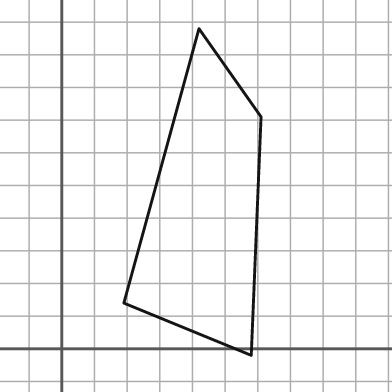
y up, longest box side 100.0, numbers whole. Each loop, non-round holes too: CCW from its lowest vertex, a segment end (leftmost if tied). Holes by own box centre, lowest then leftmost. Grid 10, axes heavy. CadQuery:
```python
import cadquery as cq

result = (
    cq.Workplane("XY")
    .moveTo(58.0, -2.0)
    .lineTo(61.0, 71.0)
    .lineTo(42.0, 98.0)
    .lineTo(19.0, 14.0)
    .close()
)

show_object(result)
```